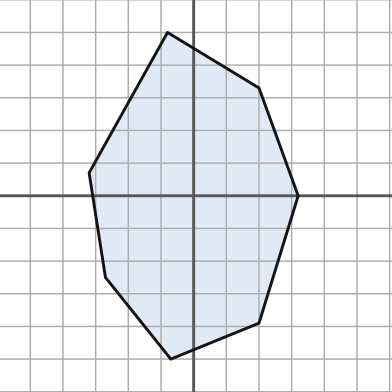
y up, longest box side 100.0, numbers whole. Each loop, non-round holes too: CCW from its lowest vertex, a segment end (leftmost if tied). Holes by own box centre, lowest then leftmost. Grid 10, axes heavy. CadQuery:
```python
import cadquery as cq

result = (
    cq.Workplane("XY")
    .moveTo(-7.0, -50.0)
    .lineTo(20.0, -39.0)
    .lineTo(32.0, 0.0)
    .lineTo(20.0, 33.0)
    .lineTo(-8.0, 50.0)
    .lineTo(-32.0, 7.0)
    .lineTo(-27.0, -25.0)
    .close()
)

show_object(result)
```